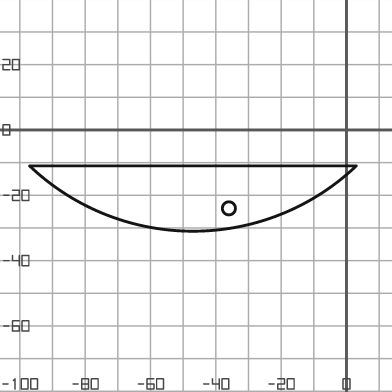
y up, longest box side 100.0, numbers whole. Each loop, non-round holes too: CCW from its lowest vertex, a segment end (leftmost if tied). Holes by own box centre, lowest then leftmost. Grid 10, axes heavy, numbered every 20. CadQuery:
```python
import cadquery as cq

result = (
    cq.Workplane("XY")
    .moveTo(-97.0, -11.0)
    .threePointArc((-47.0, -31.0), (3.0, -11.0))
    .close()
    .moveTo(-36.0, -24.0)
    .circle(2.0)
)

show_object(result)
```